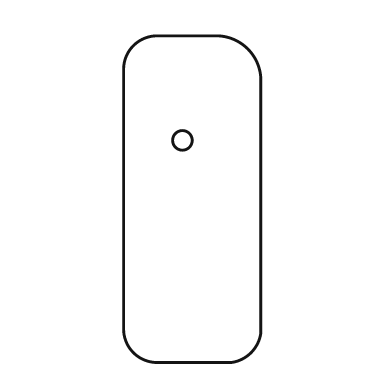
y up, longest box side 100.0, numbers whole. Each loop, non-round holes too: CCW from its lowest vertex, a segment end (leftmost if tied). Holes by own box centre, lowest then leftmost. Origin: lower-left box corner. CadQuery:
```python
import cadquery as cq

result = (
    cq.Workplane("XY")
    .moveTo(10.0, 0.0)
    .lineTo(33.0, 0.0)
    .threePointArc((39.0, 3.0), (42.0, 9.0))
    .lineTo(42.0, 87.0)
    .threePointArc((38.0, 96.0), (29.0, 100.0))
    .lineTo(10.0, 100.0)
    .threePointArc((3.0, 97.0), (0.0, 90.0))
    .lineTo(0.0, 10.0)
    .threePointArc((3.0, 3.0), (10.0, 0.0))
    .close()
    .moveTo(18.0, 68.0)
    .circle(3.0)
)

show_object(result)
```